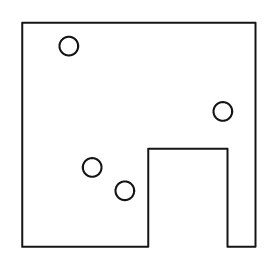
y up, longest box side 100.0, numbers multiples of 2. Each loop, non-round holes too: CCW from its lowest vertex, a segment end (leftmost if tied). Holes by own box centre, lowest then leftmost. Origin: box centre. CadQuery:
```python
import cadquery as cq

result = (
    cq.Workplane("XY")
    .moveTo(-50.0, -48.0)
    .lineTo(4.0, -48.0)
    .lineTo(4.0, -6.0)
    .lineTo(38.0, -6.0)
    .lineTo(38.0, -48.0)
    .lineTo(50.0, -48.0)
    .lineTo(50.0, 48.0)
    .lineTo(-50.0, 48.0)
    .close()
    .moveTo(-6.0, -24.0)
    .circle(4.0)
    .moveTo(-20.0, -14.0)
    .circle(4.0)
    .moveTo(36.0, 10.0)
    .circle(4.0)
    .moveTo(-30.0, 38.0)
    .circle(4.0)
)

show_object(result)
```